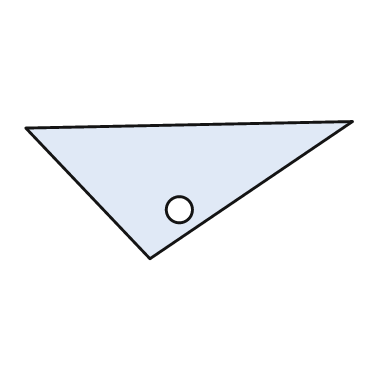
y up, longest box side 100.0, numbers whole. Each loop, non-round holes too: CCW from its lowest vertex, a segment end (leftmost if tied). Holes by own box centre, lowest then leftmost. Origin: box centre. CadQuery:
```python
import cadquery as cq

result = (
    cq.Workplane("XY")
    .moveTo(-12.0, -21.0)
    .lineTo(50.0, 21.0)
    .lineTo(-50.0, 19.0)
    .close()
    .moveTo(-3.0, -6.0)
    .circle(4.0)
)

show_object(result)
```